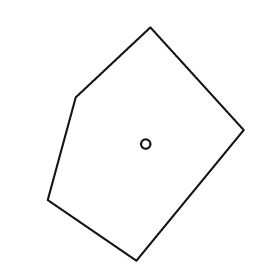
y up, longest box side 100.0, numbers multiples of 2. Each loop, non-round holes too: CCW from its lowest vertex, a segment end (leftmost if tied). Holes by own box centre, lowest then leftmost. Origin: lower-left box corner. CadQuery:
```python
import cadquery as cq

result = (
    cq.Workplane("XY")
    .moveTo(38.0, 0.0)
    .lineTo(84.0, 56.0)
    .lineTo(44.0, 100.0)
    .lineTo(12.0, 70.0)
    .lineTo(0.0, 26.0)
    .close()
    .moveTo(42.0, 50.0)
    .circle(2.0)
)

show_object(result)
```